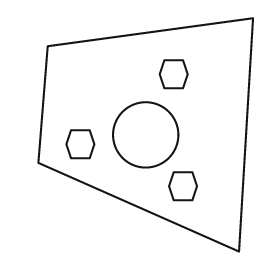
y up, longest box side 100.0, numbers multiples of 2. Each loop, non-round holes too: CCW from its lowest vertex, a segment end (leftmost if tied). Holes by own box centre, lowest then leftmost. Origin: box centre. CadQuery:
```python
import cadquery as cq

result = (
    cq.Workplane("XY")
    .moveTo(40.0, -50.0)
    .lineTo(46.0, 50.0)
    .lineTo(-42.0, 38.0)
    .lineTo(-46.0, -12.0)
    .close()
    .moveTo(12.0, -28.0)
    .lineTo(20.0, -28.0)
    .lineTo(22.0, -22.0)
    .lineTo(20.0, -16.0)
    .lineTo(12.0, -16.0)
    .lineTo(10.0, -22.0)
    .close()
    .moveTo(-32.0, -10.0)
    .lineTo(-24.0, -10.0)
    .lineTo(-22.0, -4.0)
    .lineTo(-24.0, 2.0)
    .lineTo(-32.0, 2.0)
    .lineTo(-34.0, -4.0)
    .close()
    .moveTo(0.0, 0.0)
    .circle(14.0)
    .moveTo(8.0, 20.0)
    .lineTo(16.0, 20.0)
    .lineTo(18.0, 26.0)
    .lineTo(16.0, 32.0)
    .lineTo(8.0, 32.0)
    .lineTo(6.0, 26.0)
    .close()
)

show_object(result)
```